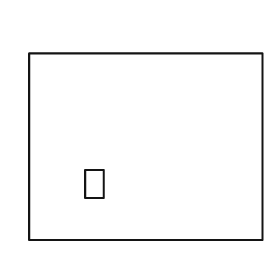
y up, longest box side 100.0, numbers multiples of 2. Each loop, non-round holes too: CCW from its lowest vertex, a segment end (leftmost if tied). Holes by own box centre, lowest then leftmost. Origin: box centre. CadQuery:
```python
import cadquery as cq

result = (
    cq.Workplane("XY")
    .moveTo(-50.0, -40.0)
    .lineTo(50.0, -40.0)
    .lineTo(50.0, 40.0)
    .lineTo(-50.0, 40.0)
    .close()
    .moveTo(-26.0, -22.0)
    .lineTo(-18.0, -22.0)
    .lineTo(-18.0, -10.0)
    .lineTo(-26.0, -10.0)
    .close()
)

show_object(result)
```